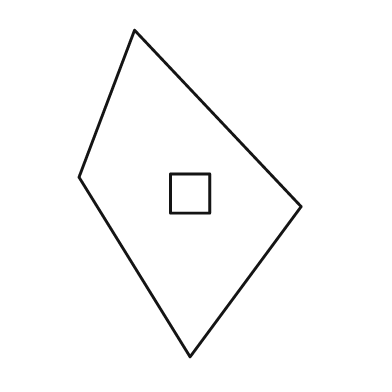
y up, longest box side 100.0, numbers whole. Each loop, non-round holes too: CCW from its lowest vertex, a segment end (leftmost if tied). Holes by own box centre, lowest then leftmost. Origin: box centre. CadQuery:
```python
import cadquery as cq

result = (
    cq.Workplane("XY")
    .moveTo(0.0, -50.0)
    .lineTo(34.0, -4.0)
    .lineTo(-17.0, 50.0)
    .lineTo(-34.0, 5.0)
    .close()
    .moveTo(-6.0, -6.0)
    .lineTo(6.0, -6.0)
    .lineTo(6.0, 6.0)
    .lineTo(-6.0, 6.0)
    .close()
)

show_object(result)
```